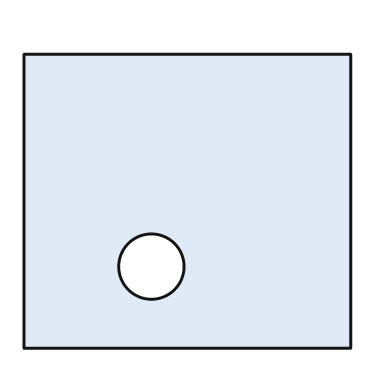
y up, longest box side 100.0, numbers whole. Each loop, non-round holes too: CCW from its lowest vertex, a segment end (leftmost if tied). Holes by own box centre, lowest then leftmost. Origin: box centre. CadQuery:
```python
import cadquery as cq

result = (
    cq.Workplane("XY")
    .moveTo(-50.0, -45.0)
    .lineTo(50.0, -45.0)
    .lineTo(50.0, 45.0)
    .lineTo(-50.0, 45.0)
    .close()
    .moveTo(-11.0, -20.0)
    .circle(10.0)
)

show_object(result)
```